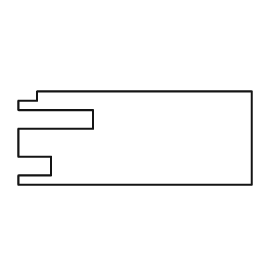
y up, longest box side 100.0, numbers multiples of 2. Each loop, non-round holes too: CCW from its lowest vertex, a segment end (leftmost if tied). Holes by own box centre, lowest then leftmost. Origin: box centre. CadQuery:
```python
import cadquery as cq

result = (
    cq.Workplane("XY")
    .moveTo(-50.0, -20.0)
    .lineTo(50.0, -20.0)
    .lineTo(50.0, 20.0)
    .lineTo(-42.0, 20.0)
    .lineTo(-42.0, 16.0)
    .lineTo(-50.0, 16.0)
    .lineTo(-50.0, 12.0)
    .lineTo(-18.0, 12.0)
    .lineTo(-18.0, 4.0)
    .lineTo(-50.0, 4.0)
    .lineTo(-50.0, -8.0)
    .lineTo(-36.0, -8.0)
    .lineTo(-36.0, -16.0)
    .lineTo(-50.0, -16.0)
    .close()
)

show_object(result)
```